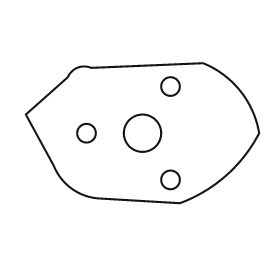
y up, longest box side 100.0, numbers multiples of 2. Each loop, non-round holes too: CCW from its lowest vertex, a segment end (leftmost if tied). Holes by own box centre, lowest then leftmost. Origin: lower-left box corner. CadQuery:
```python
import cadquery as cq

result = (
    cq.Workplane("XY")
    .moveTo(66.0, 0.0)
    .threePointArc((86.0, 12.0), (100.0, 30.0))
    .threePointArc((92.0, 48.0), (76.0, 60.0))
    .lineTo(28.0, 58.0)
    .threePointArc((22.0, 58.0), (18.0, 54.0))
    .lineTo(0.0, 38.0)
    .lineTo(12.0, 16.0)
    .threePointArc((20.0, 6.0), (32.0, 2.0))
    .close()
    .moveTo(62.0, 10.0)
    .circle(4.0)
    .moveTo(26.0, 30.0)
    .circle(4.0)
    .moveTo(50.0, 30.0)
    .circle(8.0)
    .moveTo(62.0, 50.0)
    .circle(4.0)
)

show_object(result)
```